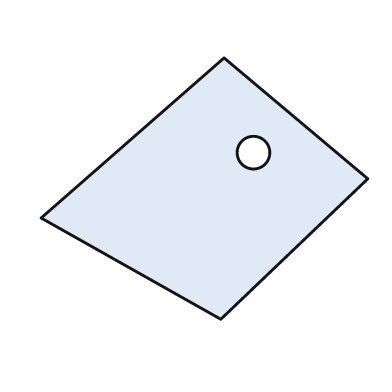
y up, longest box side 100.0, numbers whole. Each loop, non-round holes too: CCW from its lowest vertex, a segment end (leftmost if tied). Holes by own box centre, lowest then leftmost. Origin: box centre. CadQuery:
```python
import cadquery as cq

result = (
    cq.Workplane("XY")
    .moveTo(5.0, -40.0)
    .lineTo(50.0, 3.0)
    .lineTo(6.0, 40.0)
    .lineTo(-50.0, -9.0)
    .close()
    .moveTo(15.0, 11.0)
    .circle(5.0)
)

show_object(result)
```